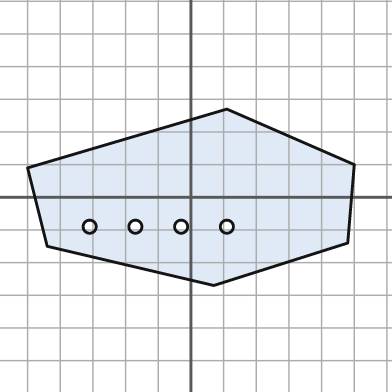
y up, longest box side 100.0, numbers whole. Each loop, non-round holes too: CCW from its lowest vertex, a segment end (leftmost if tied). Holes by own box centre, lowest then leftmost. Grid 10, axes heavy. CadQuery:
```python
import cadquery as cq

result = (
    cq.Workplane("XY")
    .moveTo(7.0, -27.0)
    .lineTo(48.0, -14.0)
    .lineTo(50.0, 10.0)
    .lineTo(11.0, 27.0)
    .lineTo(-50.0, 9.0)
    .lineTo(-44.0, -15.0)
    .close()
    .moveTo(-31.0, -9.0)
    .circle(2.0)
    .moveTo(-17.0, -9.0)
    .circle(2.0)
    .moveTo(-3.0, -9.0)
    .circle(2.0)
    .moveTo(11.0, -9.0)
    .circle(2.0)
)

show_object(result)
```